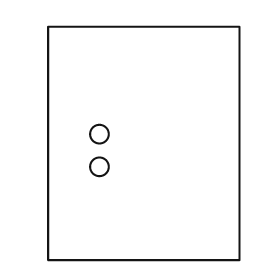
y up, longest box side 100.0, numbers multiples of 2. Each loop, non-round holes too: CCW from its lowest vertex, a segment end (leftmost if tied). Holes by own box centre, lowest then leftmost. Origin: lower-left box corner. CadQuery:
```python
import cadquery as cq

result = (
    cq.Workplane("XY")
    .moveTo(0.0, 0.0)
    .lineTo(82.0, 0.0)
    .lineTo(82.0, 100.0)
    .lineTo(0.0, 100.0)
    .close()
    .moveTo(22.0, 40.0)
    .circle(4.0)
    .moveTo(22.0, 54.0)
    .circle(4.0)
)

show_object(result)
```